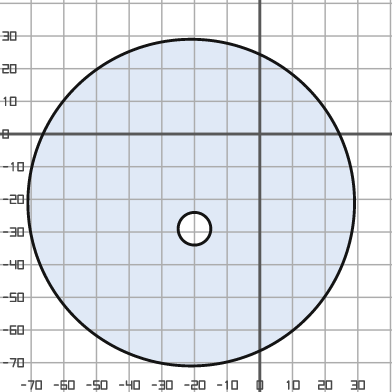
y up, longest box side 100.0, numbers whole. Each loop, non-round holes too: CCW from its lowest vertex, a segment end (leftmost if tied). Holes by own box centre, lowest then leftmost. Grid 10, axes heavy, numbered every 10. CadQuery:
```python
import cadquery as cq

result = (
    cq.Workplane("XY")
    .moveTo(-21.0, -21.0)
    .circle(50.0)
    .moveTo(-20.0, -29.0)
    .circle(5.0)
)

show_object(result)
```